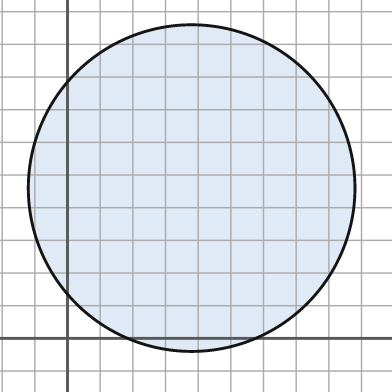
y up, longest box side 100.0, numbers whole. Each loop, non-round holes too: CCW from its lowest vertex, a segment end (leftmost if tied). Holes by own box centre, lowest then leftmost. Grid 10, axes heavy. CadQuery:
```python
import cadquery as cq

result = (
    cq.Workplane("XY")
    .moveTo(38.0, 46.0)
    .circle(50.0)
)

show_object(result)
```